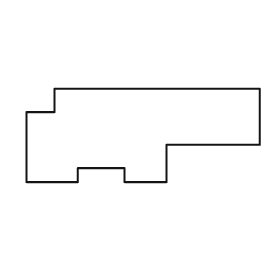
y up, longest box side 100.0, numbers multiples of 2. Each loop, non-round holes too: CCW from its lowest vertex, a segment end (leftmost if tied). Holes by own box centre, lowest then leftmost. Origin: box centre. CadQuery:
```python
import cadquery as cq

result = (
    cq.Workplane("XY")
    .moveTo(-50.0, -20.0)
    .lineTo(-28.0, -20.0)
    .lineTo(-28.0, -14.0)
    .lineTo(-8.0, -14.0)
    .lineTo(-8.0, -20.0)
    .lineTo(10.0, -20.0)
    .lineTo(10.0, -4.0)
    .lineTo(50.0, -4.0)
    .lineTo(50.0, 20.0)
    .lineTo(-38.0, 20.0)
    .lineTo(-38.0, 10.0)
    .lineTo(-50.0, 10.0)
    .close()
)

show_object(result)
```